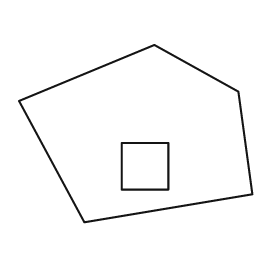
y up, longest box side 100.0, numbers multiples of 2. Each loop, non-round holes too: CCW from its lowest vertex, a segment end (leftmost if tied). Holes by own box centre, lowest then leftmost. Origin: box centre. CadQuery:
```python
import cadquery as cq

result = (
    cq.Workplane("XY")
    .moveTo(-22.0, -38.0)
    .lineTo(50.0, -26.0)
    .lineTo(44.0, 18.0)
    .lineTo(8.0, 38.0)
    .lineTo(-50.0, 14.0)
    .close()
    .moveTo(-6.0, -24.0)
    .lineTo(14.0, -24.0)
    .lineTo(14.0, -4.0)
    .lineTo(-6.0, -4.0)
    .close()
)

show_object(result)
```